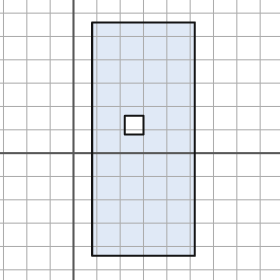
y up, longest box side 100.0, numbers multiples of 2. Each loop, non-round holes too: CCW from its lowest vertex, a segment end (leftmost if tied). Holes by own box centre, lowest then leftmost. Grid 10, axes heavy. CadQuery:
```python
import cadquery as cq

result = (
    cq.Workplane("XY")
    .moveTo(8.0, -44.0)
    .lineTo(52.0, -44.0)
    .lineTo(52.0, 56.0)
    .lineTo(8.0, 56.0)
    .close()
    .moveTo(22.0, 8.0)
    .lineTo(30.0, 8.0)
    .lineTo(30.0, 16.0)
    .lineTo(22.0, 16.0)
    .close()
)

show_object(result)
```